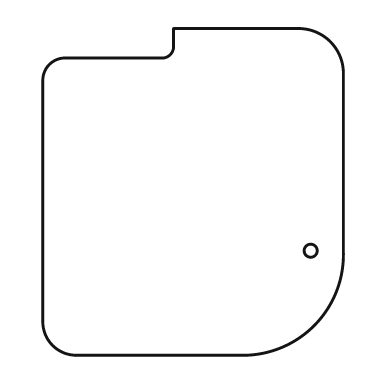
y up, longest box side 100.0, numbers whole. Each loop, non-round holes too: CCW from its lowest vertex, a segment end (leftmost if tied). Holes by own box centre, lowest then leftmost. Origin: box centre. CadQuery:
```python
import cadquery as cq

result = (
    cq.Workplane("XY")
    .moveTo(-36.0, -50.0)
    .lineTo(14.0, -50.0)
    .threePointArc((37.0, -41.0), (46.0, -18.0))
    .lineTo(46.0, 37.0)
    .threePointArc((42.0, 46.0), (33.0, 50.0))
    .lineTo(-6.0, 50.0)
    .lineTo(-6.0, 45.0)
    .threePointArc((-7.0, 42.0), (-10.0, 41.0))
    .lineTo(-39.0, 41.0)
    .threePointArc((-44.0, 39.0), (-46.0, 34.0))
    .lineTo(-46.0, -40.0)
    .threePointArc((-43.0, -47.0), (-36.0, -50.0))
    .close()
    .moveTo(36.0, -18.0)
    .circle(2.0)
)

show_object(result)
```